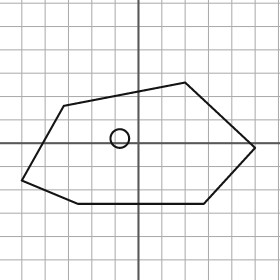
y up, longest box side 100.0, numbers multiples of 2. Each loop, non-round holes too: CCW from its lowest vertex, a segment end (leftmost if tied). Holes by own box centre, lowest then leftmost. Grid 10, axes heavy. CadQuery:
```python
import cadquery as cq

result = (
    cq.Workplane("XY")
    .moveTo(-26.0, -26.0)
    .lineTo(28.0, -26.0)
    .lineTo(50.0, -2.0)
    .lineTo(20.0, 26.0)
    .lineTo(-32.0, 16.0)
    .lineTo(-50.0, -16.0)
    .close()
    .moveTo(-8.0, 2.0)
    .circle(4.0)
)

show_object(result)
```